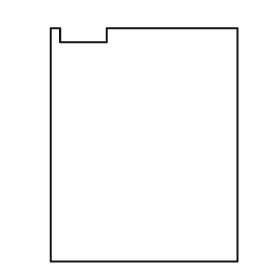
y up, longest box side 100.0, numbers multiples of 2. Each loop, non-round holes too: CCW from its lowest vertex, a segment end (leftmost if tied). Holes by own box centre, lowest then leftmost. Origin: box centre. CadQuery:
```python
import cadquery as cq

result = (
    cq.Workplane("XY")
    .moveTo(-40.0, -50.0)
    .lineTo(40.0, -50.0)
    .lineTo(40.0, 50.0)
    .lineTo(-16.0, 50.0)
    .lineTo(-16.0, 44.0)
    .lineTo(-36.0, 44.0)
    .lineTo(-36.0, 50.0)
    .lineTo(-40.0, 50.0)
    .close()
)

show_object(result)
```